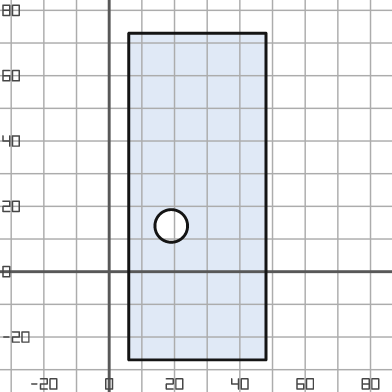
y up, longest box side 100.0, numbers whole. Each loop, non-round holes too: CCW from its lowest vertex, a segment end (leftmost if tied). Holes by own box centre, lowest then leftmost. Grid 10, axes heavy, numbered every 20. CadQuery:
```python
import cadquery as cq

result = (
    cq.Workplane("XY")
    .moveTo(6.0, -27.0)
    .lineTo(48.0, -27.0)
    .lineTo(48.0, 73.0)
    .lineTo(6.0, 73.0)
    .close()
    .moveTo(19.0, 14.0)
    .circle(5.0)
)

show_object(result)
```